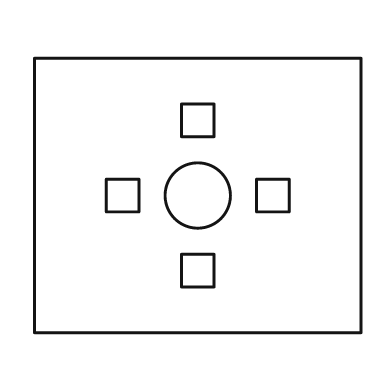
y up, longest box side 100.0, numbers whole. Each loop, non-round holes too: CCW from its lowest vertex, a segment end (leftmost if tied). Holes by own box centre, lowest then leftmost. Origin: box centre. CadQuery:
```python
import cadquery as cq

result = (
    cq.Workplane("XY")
    .moveTo(-50.0, -42.0)
    .lineTo(50.0, -42.0)
    .lineTo(50.0, 42.0)
    .lineTo(-50.0, 42.0)
    .close()
    .moveTo(-5.0, -28.0)
    .lineTo(5.0, -28.0)
    .lineTo(5.0, -18.0)
    .lineTo(-5.0, -18.0)
    .close()
    .moveTo(-28.0, -5.0)
    .lineTo(-18.0, -5.0)
    .lineTo(-18.0, 5.0)
    .lineTo(-28.0, 5.0)
    .close()
    .moveTo(0.0, 0.0)
    .circle(10.0)
    .moveTo(18.0, -5.0)
    .lineTo(28.0, -5.0)
    .lineTo(28.0, 5.0)
    .lineTo(18.0, 5.0)
    .close()
    .moveTo(-5.0, 18.0)
    .lineTo(5.0, 18.0)
    .lineTo(5.0, 28.0)
    .lineTo(-5.0, 28.0)
    .close()
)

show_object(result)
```